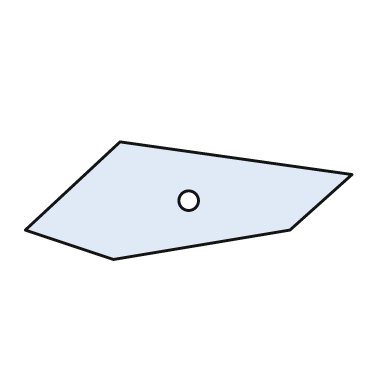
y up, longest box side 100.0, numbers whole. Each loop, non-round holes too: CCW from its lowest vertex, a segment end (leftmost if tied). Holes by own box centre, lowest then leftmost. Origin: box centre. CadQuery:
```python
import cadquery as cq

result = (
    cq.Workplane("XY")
    .moveTo(-23.0, -18.0)
    .lineTo(31.0, -9.0)
    .lineTo(50.0, 8.0)
    .lineTo(-21.0, 18.0)
    .lineTo(-50.0, -9.0)
    .close()
    .moveTo(0.0, 0.0)
    .circle(3.0)
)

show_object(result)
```